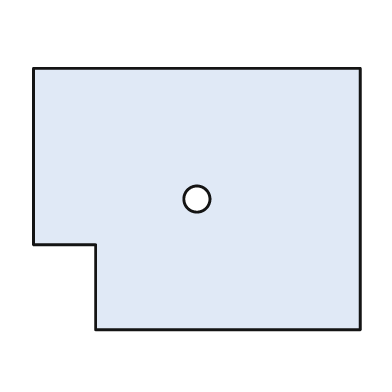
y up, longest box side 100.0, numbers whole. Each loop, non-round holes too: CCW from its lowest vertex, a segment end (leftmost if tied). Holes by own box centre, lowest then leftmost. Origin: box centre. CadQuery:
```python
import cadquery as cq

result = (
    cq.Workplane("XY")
    .moveTo(-31.0, -40.0)
    .lineTo(50.0, -40.0)
    .lineTo(50.0, 40.0)
    .lineTo(-50.0, 40.0)
    .lineTo(-50.0, -14.0)
    .lineTo(-31.0, -14.0)
    .close()
    .moveTo(0.0, 0.0)
    .circle(4.0)
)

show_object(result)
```